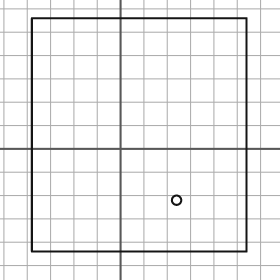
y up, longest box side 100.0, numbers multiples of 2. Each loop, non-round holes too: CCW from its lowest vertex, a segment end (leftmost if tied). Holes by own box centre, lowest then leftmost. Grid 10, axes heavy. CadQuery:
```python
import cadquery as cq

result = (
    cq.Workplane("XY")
    .moveTo(-38.0, -44.0)
    .lineTo(54.0, -44.0)
    .lineTo(54.0, 56.0)
    .lineTo(-38.0, 56.0)
    .close()
    .moveTo(24.0, -22.0)
    .circle(2.0)
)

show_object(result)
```